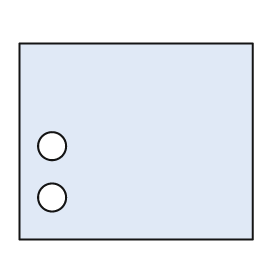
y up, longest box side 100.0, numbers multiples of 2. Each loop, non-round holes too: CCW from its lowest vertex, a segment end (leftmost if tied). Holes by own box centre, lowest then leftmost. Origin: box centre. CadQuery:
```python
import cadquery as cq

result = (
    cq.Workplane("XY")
    .moveTo(-50.0, -42.0)
    .lineTo(50.0, -42.0)
    .lineTo(50.0, 42.0)
    .lineTo(-50.0, 42.0)
    .close()
    .moveTo(-36.0, -24.0)
    .circle(6.0)
    .moveTo(-36.0, -2.0)
    .circle(6.0)
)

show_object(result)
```